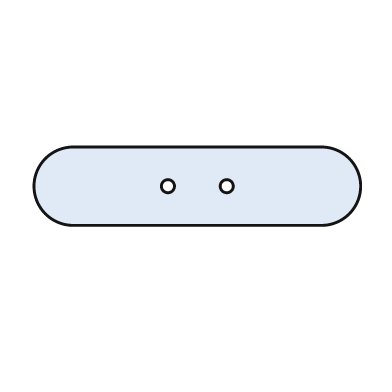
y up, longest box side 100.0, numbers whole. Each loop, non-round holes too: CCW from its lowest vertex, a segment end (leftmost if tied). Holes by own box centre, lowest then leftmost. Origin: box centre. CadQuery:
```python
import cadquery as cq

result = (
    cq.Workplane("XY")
    .moveTo(-38.0, -12.0)
    .lineTo(38.0, -12.0)
    .threePointArc((50.0, 0.0), (38.0, 12.0))
    .lineTo(-38.0, 12.0)
    .threePointArc((-50.0, 0.0), (-38.0, -12.0))
    .close()
    .moveTo(-9.0, 0.0)
    .circle(2.0)
    .moveTo(9.0, 0.0)
    .circle(2.0)
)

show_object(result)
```